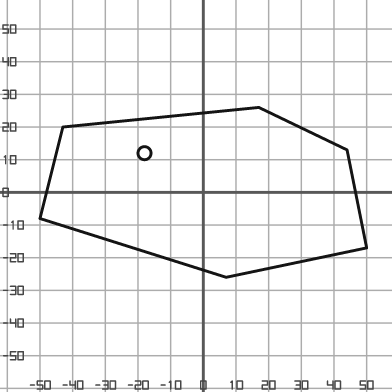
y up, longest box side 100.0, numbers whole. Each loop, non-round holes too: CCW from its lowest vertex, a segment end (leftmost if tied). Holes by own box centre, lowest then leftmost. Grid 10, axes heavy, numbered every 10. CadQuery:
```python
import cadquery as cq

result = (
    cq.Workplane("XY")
    .moveTo(7.0, -26.0)
    .lineTo(50.0, -17.0)
    .lineTo(44.0, 13.0)
    .lineTo(17.0, 26.0)
    .lineTo(-43.0, 20.0)
    .lineTo(-50.0, -8.0)
    .close()
    .moveTo(-18.0, 12.0)
    .circle(2.0)
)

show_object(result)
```